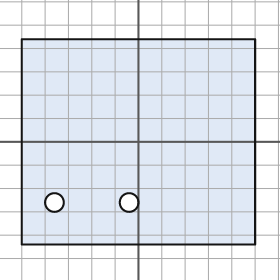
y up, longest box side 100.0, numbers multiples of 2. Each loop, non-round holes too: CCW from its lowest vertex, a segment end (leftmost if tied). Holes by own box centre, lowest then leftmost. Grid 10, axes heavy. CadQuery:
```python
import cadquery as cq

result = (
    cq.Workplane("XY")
    .moveTo(-50.0, -44.0)
    .lineTo(50.0, -44.0)
    .lineTo(50.0, 44.0)
    .lineTo(-50.0, 44.0)
    .close()
    .moveTo(-36.0, -26.0)
    .circle(4.0)
    .moveTo(-4.0, -26.0)
    .circle(4.0)
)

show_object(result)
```